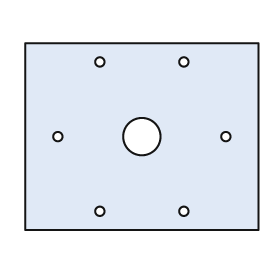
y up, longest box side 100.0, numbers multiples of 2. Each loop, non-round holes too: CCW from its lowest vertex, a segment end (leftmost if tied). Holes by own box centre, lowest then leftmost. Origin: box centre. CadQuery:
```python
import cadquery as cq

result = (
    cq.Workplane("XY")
    .moveTo(-50.0, -40.0)
    .lineTo(50.0, -40.0)
    .lineTo(50.0, 40.0)
    .lineTo(-50.0, 40.0)
    .close()
    .moveTo(-18.0, -32.0)
    .circle(2.0)
    .moveTo(18.0, -32.0)
    .circle(2.0)
    .moveTo(-36.0, 0.0)
    .circle(2.0)
    .moveTo(0.0, 0.0)
    .circle(8.0)
    .moveTo(36.0, 0.0)
    .circle(2.0)
    .moveTo(-18.0, 32.0)
    .circle(2.0)
    .moveTo(18.0, 32.0)
    .circle(2.0)
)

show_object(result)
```